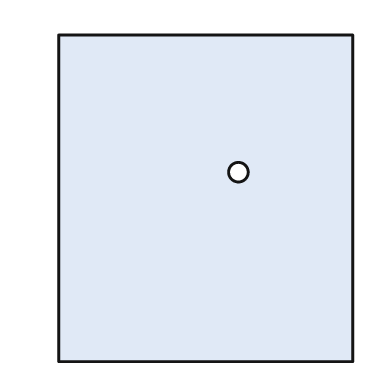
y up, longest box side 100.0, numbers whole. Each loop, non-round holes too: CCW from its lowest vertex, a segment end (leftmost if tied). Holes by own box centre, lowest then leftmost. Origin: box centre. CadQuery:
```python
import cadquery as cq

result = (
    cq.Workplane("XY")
    .moveTo(-45.0, -50.0)
    .lineTo(45.0, -50.0)
    .lineTo(45.0, 50.0)
    .lineTo(-45.0, 50.0)
    .close()
    .moveTo(10.0, 8.0)
    .circle(3.0)
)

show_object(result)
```